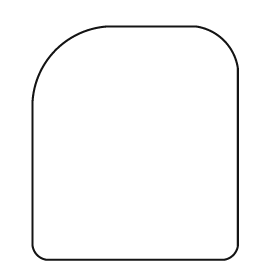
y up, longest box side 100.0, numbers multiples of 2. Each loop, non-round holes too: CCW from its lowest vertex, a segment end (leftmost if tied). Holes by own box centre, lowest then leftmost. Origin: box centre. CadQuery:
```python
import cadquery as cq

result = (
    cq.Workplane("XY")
    .moveTo(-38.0, -50.0)
    .lineTo(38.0, -50.0)
    .threePointArc((42.0, -48.0), (44.0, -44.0))
    .lineTo(44.0, 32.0)
    .threePointArc((38.0, 44.0), (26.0, 50.0))
    .lineTo(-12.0, 50.0)
    .threePointArc((-34.0, 40.0), (-44.0, 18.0))
    .lineTo(-44.0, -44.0)
    .threePointArc((-42.0, -48.0), (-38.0, -50.0))
    .close()
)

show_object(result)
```